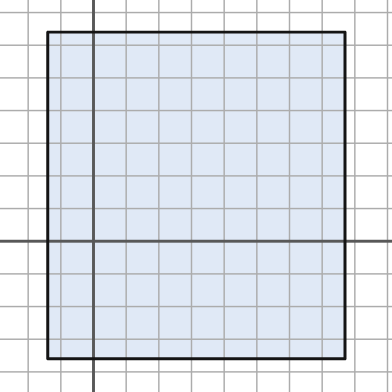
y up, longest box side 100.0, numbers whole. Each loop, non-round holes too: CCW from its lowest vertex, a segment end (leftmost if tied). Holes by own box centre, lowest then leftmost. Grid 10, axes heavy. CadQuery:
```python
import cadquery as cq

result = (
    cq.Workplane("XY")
    .moveTo(-14.0, -36.0)
    .lineTo(77.0, -36.0)
    .lineTo(77.0, 64.0)
    .lineTo(-14.0, 64.0)
    .close()
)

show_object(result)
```